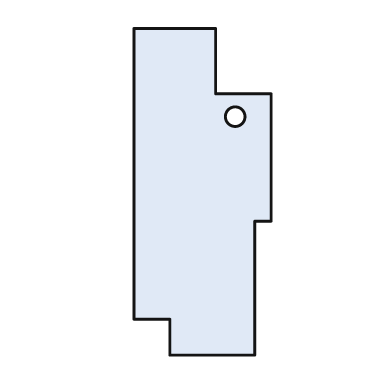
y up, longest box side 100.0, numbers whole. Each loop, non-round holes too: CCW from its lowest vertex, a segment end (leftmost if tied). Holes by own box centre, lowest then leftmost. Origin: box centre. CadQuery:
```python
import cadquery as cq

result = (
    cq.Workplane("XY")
    .moveTo(-10.0, -50.0)
    .lineTo(16.0, -50.0)
    .lineTo(16.0, -9.0)
    .lineTo(21.0, -9.0)
    .lineTo(21.0, 30.0)
    .lineTo(4.0, 30.0)
    .lineTo(4.0, 50.0)
    .lineTo(-21.0, 50.0)
    .lineTo(-21.0, -39.0)
    .lineTo(-10.0, -39.0)
    .close()
    .moveTo(10.0, 23.0)
    .circle(3.0)
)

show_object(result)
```